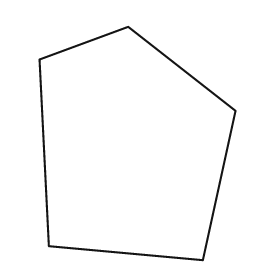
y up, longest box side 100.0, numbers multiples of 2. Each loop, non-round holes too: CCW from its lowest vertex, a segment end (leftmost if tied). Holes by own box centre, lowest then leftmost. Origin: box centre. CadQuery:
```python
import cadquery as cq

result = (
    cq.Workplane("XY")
    .moveTo(28.0, -50.0)
    .lineTo(42.0, 14.0)
    .lineTo(-4.0, 50.0)
    .lineTo(-42.0, 36.0)
    .lineTo(-38.0, -44.0)
    .close()
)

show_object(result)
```